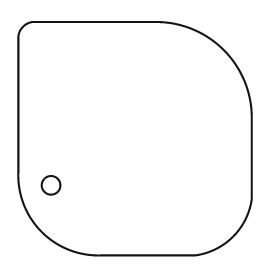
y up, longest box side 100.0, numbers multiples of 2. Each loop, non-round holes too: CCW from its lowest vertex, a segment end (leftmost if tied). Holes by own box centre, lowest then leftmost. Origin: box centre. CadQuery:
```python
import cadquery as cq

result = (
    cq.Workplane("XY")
    .moveTo(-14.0, -50.0)
    .lineTo(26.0, -50.0)
    .threePointArc((42.0, -42.0), (50.0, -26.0))
    .lineTo(50.0, 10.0)
    .threePointArc((38.0, 38.0), (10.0, 50.0))
    .lineTo(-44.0, 50.0)
    .threePointArc((-48.0, 48.0), (-50.0, 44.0))
    .lineTo(-50.0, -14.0)
    .threePointArc((-40.0, -40.0), (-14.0, -50.0))
    .close()
    .moveTo(-36.0, -20.0)
    .circle(4.0)
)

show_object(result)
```